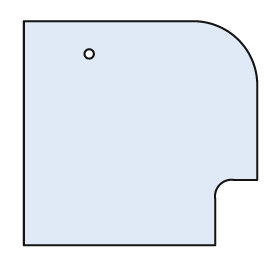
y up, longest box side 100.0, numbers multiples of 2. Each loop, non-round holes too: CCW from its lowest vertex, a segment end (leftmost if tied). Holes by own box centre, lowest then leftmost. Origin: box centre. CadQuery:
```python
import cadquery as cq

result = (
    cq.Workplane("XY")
    .moveTo(-50.0, -48.0)
    .lineTo(32.0, -48.0)
    .lineTo(32.0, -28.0)
    .threePointArc((34.0, -22.0), (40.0, -20.0))
    .lineTo(50.0, -20.0)
    .lineTo(50.0, 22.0)
    .threePointArc((42.0, 40.0), (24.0, 48.0))
    .lineTo(-50.0, 48.0)
    .close()
    .moveTo(-22.0, 34.0)
    .circle(2.0)
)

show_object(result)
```